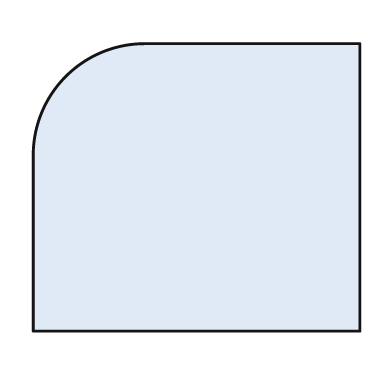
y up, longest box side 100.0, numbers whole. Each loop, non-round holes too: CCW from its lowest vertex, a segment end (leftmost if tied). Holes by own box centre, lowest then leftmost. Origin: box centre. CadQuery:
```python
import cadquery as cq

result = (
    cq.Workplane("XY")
    .moveTo(-50.0, -44.0)
    .lineTo(50.0, -44.0)
    .lineTo(50.0, 44.0)
    .lineTo(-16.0, 44.0)
    .threePointArc((-40.0, 34.0), (-50.0, 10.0))
    .close()
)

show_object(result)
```